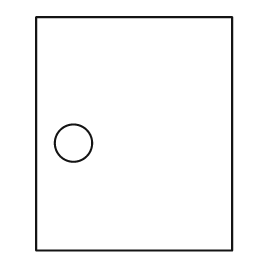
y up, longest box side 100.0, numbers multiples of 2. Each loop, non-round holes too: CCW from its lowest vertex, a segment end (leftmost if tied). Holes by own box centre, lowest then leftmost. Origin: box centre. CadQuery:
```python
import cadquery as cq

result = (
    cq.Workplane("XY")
    .moveTo(-42.0, -50.0)
    .lineTo(42.0, -50.0)
    .lineTo(42.0, 50.0)
    .lineTo(-42.0, 50.0)
    .close()
    .moveTo(-26.0, -4.0)
    .circle(8.0)
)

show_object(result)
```